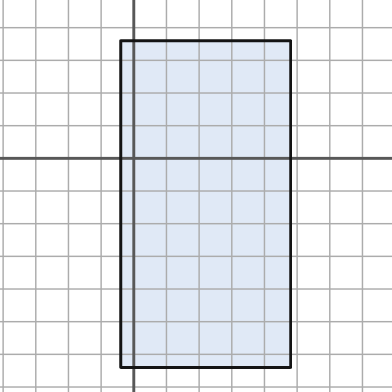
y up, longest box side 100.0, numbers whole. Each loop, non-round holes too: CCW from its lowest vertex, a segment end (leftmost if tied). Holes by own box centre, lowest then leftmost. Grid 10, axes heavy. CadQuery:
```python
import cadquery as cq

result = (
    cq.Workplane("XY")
    .moveTo(-4.0, -64.0)
    .lineTo(48.0, -64.0)
    .lineTo(48.0, 36.0)
    .lineTo(-4.0, 36.0)
    .close()
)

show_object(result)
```